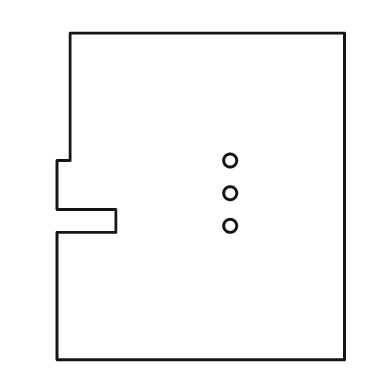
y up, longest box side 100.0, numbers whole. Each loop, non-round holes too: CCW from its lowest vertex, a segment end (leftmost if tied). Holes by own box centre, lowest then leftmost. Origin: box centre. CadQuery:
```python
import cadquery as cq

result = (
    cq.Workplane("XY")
    .moveTo(-44.0, -50.0)
    .lineTo(44.0, -50.0)
    .lineTo(44.0, 50.0)
    .lineTo(-40.0, 50.0)
    .lineTo(-40.0, 11.0)
    .lineTo(-44.0, 11.0)
    .lineTo(-44.0, -4.0)
    .lineTo(-26.0, -4.0)
    .lineTo(-26.0, -11.0)
    .lineTo(-44.0, -11.0)
    .close()
    .moveTo(9.0, -9.0)
    .circle(2.0)
    .moveTo(9.0, 1.0)
    .circle(2.0)
    .moveTo(9.0, 11.0)
    .circle(2.0)
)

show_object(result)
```